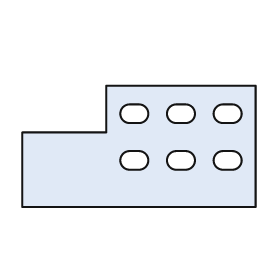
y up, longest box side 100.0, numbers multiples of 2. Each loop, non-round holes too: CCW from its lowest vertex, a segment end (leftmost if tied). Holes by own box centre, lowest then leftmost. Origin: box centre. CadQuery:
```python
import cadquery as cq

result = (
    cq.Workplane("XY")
    .moveTo(-50.0, -26.0)
    .lineTo(50.0, -26.0)
    .lineTo(50.0, 26.0)
    .lineTo(-14.0, 26.0)
    .lineTo(-14.0, 6.0)
    .lineTo(-50.0, 6.0)
    .close()
    .moveTo(-4.0, -10.0)
    .lineTo(0.0, -10.0)
    .threePointArc((4.0, -6.0), (0.0, -2.0))
    .lineTo(-4.0, -2.0)
    .threePointArc((-8.0, -6.0), (-4.0, -10.0))
    .close()
    .moveTo(16.0, -10.0)
    .lineTo(20.0, -10.0)
    .threePointArc((24.0, -6.0), (20.0, -2.0))
    .lineTo(16.0, -2.0)
    .threePointArc((12.0, -6.0), (16.0, -10.0))
    .close()
    .moveTo(36.0, -10.0)
    .lineTo(40.0, -10.0)
    .threePointArc((44.0, -6.0), (40.0, -2.0))
    .lineTo(36.0, -2.0)
    .threePointArc((32.0, -6.0), (36.0, -10.0))
    .close()
    .moveTo(-4.0, 10.0)
    .lineTo(0.0, 10.0)
    .threePointArc((4.0, 14.0), (0.0, 18.0))
    .lineTo(-4.0, 18.0)
    .threePointArc((-8.0, 14.0), (-4.0, 10.0))
    .close()
    .moveTo(16.0, 10.0)
    .lineTo(20.0, 10.0)
    .threePointArc((24.0, 14.0), (20.0, 18.0))
    .lineTo(16.0, 18.0)
    .threePointArc((12.0, 14.0), (16.0, 10.0))
    .close()
    .moveTo(36.0, 10.0)
    .lineTo(40.0, 10.0)
    .threePointArc((44.0, 14.0), (40.0, 18.0))
    .lineTo(36.0, 18.0)
    .threePointArc((32.0, 14.0), (36.0, 10.0))
    .close()
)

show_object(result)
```